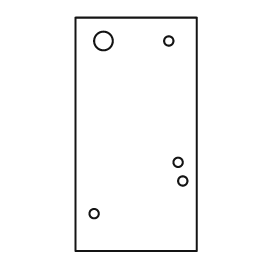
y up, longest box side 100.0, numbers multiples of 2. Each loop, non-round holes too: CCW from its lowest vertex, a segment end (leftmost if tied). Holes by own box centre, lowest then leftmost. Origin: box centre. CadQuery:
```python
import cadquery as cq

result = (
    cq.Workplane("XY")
    .moveTo(-26.0, -50.0)
    .lineTo(26.0, -50.0)
    .lineTo(26.0, 50.0)
    .lineTo(-26.0, 50.0)
    .close()
    .moveTo(-18.0, -34.0)
    .circle(2.0)
    .moveTo(20.0, -20.0)
    .circle(2.0)
    .moveTo(18.0, -12.0)
    .circle(2.0)
    .moveTo(-14.0, 40.0)
    .circle(4.0)
    .moveTo(14.0, 40.0)
    .circle(2.0)
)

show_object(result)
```